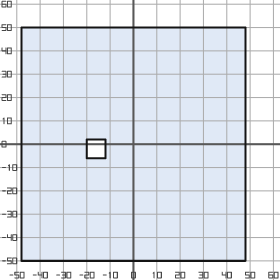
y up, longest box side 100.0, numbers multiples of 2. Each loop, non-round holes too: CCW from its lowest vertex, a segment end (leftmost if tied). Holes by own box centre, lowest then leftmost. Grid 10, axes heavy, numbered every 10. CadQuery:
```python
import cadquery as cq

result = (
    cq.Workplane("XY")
    .moveTo(-48.0, -50.0)
    .lineTo(48.0, -50.0)
    .lineTo(48.0, 50.0)
    .lineTo(-48.0, 50.0)
    .close()
    .moveTo(-20.0, -6.0)
    .lineTo(-12.0, -6.0)
    .lineTo(-12.0, 2.0)
    .lineTo(-20.0, 2.0)
    .close()
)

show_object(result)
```